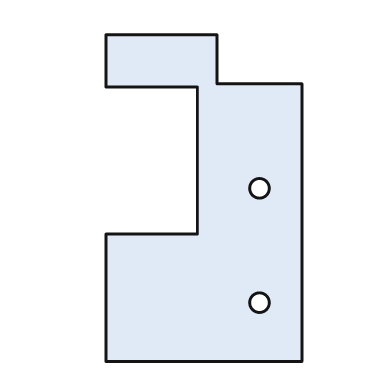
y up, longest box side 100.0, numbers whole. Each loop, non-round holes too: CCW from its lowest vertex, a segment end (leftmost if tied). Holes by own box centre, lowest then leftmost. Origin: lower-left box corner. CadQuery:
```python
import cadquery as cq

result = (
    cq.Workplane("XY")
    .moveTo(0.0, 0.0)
    .lineTo(60.0, 0.0)
    .lineTo(60.0, 85.0)
    .lineTo(34.0, 85.0)
    .lineTo(34.0, 100.0)
    .lineTo(0.0, 100.0)
    .lineTo(0.0, 84.0)
    .lineTo(28.0, 84.0)
    .lineTo(28.0, 39.0)
    .lineTo(0.0, 39.0)
    .close()
    .moveTo(47.0, 18.0)
    .circle(3.0)
    .moveTo(47.0, 53.0)
    .circle(3.0)
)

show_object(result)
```